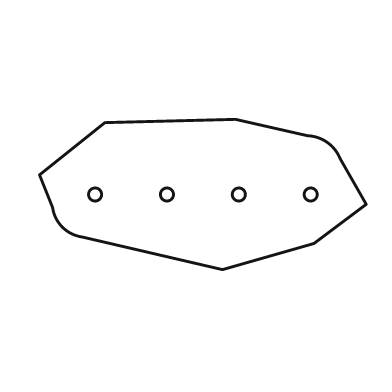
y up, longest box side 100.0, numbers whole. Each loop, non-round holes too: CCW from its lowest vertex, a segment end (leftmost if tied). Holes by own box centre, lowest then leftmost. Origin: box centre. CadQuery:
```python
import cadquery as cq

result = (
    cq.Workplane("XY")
    .moveTo(6.0, -23.0)
    .lineTo(34.0, -15.0)
    .lineTo(50.0, -3.0)
    .lineTo(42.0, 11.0)
    .threePointArc((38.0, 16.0), (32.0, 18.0))
    .lineTo(10.0, 23.0)
    .lineTo(-30.0, 22.0)
    .lineTo(-50.0, 6.0)
    .lineTo(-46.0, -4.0)
    .threePointArc((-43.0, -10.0), (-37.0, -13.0))
    .close()
    .moveTo(-33.0, 0.0)
    .circle(2.0)
    .moveTo(-11.0, 0.0)
    .circle(2.0)
    .moveTo(11.0, 0.0)
    .circle(2.0)
    .moveTo(33.0, 0.0)
    .circle(2.0)
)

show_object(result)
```